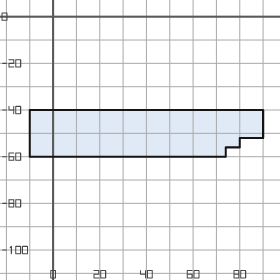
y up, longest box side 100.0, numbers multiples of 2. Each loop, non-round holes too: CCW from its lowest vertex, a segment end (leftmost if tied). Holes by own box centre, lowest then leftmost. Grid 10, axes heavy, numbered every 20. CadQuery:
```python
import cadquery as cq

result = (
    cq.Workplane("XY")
    .moveTo(-10.0, -60.0)
    .lineTo(74.0, -60.0)
    .lineTo(74.0, -56.0)
    .lineTo(80.0, -56.0)
    .lineTo(80.0, -52.0)
    .lineTo(90.0, -52.0)
    .lineTo(90.0, -40.0)
    .lineTo(-10.0, -40.0)
    .close()
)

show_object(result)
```